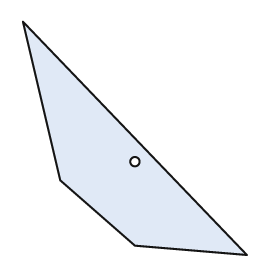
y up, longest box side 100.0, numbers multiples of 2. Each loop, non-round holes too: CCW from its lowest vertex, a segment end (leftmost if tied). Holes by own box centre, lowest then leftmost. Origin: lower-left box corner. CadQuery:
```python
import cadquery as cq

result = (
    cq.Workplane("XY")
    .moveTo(96.0, 0.0)
    .lineTo(0.0, 100.0)
    .lineTo(16.0, 32.0)
    .lineTo(48.0, 4.0)
    .close()
    .moveTo(48.0, 40.0)
    .circle(2.0)
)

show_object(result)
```